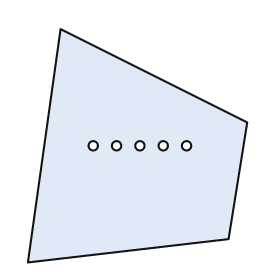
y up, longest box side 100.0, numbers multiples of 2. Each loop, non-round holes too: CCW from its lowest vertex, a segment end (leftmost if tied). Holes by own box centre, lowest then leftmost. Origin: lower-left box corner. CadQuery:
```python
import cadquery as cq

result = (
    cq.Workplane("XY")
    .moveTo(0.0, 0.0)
    .lineTo(86.0, 10.0)
    .lineTo(94.0, 60.0)
    .lineTo(14.0, 100.0)
    .close()
    .moveTo(28.0, 50.0)
    .circle(2.0)
    .moveTo(38.0, 50.0)
    .circle(2.0)
    .moveTo(48.0, 50.0)
    .circle(2.0)
    .moveTo(58.0, 50.0)
    .circle(2.0)
    .moveTo(68.0, 50.0)
    .circle(2.0)
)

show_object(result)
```